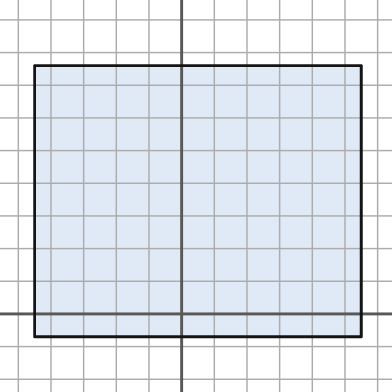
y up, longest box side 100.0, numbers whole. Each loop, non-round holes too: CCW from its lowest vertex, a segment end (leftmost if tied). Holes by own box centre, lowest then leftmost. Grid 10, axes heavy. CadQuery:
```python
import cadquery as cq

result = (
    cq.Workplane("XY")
    .moveTo(-45.0, -7.0)
    .lineTo(55.0, -7.0)
    .lineTo(55.0, 76.0)
    .lineTo(-45.0, 76.0)
    .close()
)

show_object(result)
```